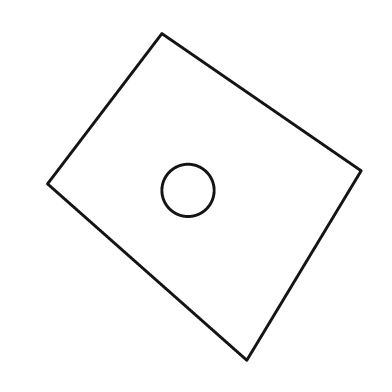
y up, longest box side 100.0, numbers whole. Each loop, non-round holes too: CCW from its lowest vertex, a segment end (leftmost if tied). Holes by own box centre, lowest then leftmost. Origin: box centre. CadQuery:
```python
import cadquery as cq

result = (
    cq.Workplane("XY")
    .moveTo(13.0, -50.0)
    .lineTo(48.0, 8.0)
    .lineTo(-13.0, 50.0)
    .lineTo(-48.0, 4.0)
    .close()
    .moveTo(-5.0, 2.0)
    .circle(8.0)
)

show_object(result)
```